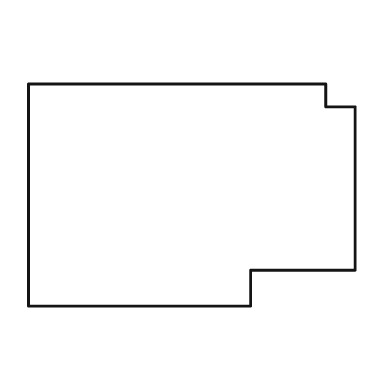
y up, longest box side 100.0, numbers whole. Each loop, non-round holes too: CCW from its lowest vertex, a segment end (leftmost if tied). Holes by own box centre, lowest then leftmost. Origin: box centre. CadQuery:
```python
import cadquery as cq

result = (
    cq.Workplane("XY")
    .moveTo(-50.0, -34.0)
    .lineTo(18.0, -34.0)
    .lineTo(18.0, -23.0)
    .lineTo(50.0, -23.0)
    .lineTo(50.0, 27.0)
    .lineTo(41.0, 27.0)
    .lineTo(41.0, 34.0)
    .lineTo(-50.0, 34.0)
    .close()
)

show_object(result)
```